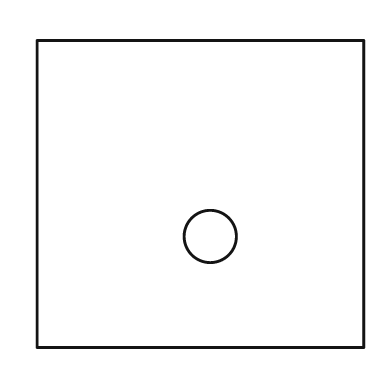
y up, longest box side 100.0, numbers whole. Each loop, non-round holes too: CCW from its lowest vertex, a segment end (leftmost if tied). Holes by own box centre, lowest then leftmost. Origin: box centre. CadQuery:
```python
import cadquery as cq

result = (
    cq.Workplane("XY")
    .moveTo(-50.0, -47.0)
    .lineTo(50.0, -47.0)
    .lineTo(50.0, 47.0)
    .lineTo(-50.0, 47.0)
    .close()
    .moveTo(3.0, -13.0)
    .circle(8.0)
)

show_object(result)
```